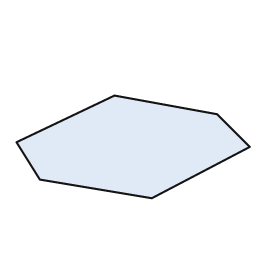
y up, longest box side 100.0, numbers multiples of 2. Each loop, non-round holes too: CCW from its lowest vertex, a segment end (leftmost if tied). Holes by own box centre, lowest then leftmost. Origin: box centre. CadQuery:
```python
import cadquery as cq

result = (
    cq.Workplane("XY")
    .moveTo(8.0, -22.0)
    .lineTo(50.0, 0.0)
    .lineTo(36.0, 14.0)
    .lineTo(-8.0, 22.0)
    .lineTo(-50.0, 2.0)
    .lineTo(-40.0, -14.0)
    .close()
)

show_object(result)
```